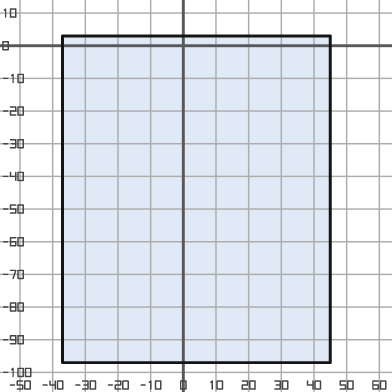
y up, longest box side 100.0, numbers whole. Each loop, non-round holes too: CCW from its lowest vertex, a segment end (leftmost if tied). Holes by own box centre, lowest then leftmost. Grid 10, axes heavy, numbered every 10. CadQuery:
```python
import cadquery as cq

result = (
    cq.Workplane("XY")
    .moveTo(-37.0, -97.0)
    .lineTo(45.0, -97.0)
    .lineTo(45.0, 3.0)
    .lineTo(-37.0, 3.0)
    .close()
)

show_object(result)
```